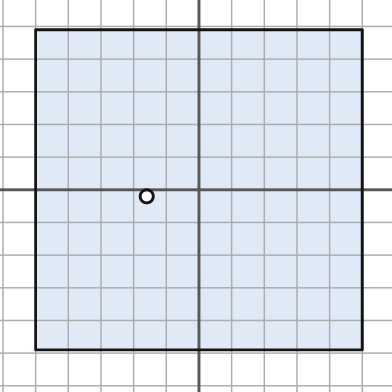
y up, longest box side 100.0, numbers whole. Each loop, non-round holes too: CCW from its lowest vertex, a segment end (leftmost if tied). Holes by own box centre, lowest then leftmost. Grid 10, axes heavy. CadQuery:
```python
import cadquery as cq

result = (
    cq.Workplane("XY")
    .moveTo(-50.0, -49.0)
    .lineTo(50.0, -49.0)
    .lineTo(50.0, 49.0)
    .lineTo(-50.0, 49.0)
    .close()
    .moveTo(-16.0, -2.0)
    .circle(2.0)
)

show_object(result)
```